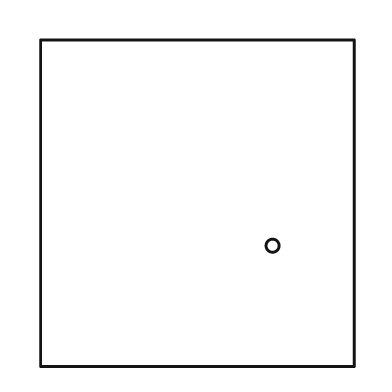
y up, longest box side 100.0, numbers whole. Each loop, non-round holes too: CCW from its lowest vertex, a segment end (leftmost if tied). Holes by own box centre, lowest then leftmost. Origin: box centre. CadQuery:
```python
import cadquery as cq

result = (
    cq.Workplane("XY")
    .moveTo(-48.0, -50.0)
    .lineTo(48.0, -50.0)
    .lineTo(48.0, 50.0)
    .lineTo(-48.0, 50.0)
    .close()
    .moveTo(23.0, -13.0)
    .circle(2.0)
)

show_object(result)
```